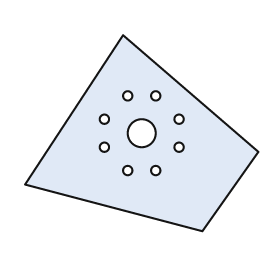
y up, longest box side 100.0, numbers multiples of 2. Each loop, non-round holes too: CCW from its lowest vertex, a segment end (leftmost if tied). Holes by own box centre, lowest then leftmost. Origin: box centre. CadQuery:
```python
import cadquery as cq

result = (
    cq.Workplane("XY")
    .moveTo(26.0, -42.0)
    .lineTo(50.0, -8.0)
    .lineTo(-8.0, 42.0)
    .lineTo(-50.0, -22.0)
    .close()
    .moveTo(-6.0, -16.0)
    .circle(2.0)
    .moveTo(6.0, -16.0)
    .circle(2.0)
    .moveTo(-16.0, -6.0)
    .circle(2.0)
    .moveTo(16.0, -6.0)
    .circle(2.0)
    .moveTo(0.0, 0.0)
    .circle(6.0)
    .moveTo(-16.0, 6.0)
    .circle(2.0)
    .moveTo(16.0, 6.0)
    .circle(2.0)
    .moveTo(-6.0, 16.0)
    .circle(2.0)
    .moveTo(6.0, 16.0)
    .circle(2.0)
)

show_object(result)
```